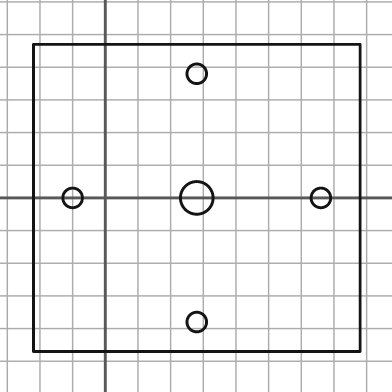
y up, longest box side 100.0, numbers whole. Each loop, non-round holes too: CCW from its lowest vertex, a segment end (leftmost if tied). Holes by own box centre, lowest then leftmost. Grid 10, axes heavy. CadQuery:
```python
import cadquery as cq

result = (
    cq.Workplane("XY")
    .moveTo(-22.0, -47.0)
    .lineTo(78.0, -47.0)
    .lineTo(78.0, 47.0)
    .lineTo(-22.0, 47.0)
    .close()
    .moveTo(28.0, -38.0)
    .circle(3.0)
    .moveTo(-10.0, 0.0)
    .circle(3.0)
    .moveTo(28.0, 0.0)
    .circle(5.0)
    .moveTo(66.0, 0.0)
    .circle(3.0)
    .moveTo(28.0, 38.0)
    .circle(3.0)
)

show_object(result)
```